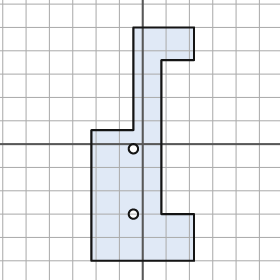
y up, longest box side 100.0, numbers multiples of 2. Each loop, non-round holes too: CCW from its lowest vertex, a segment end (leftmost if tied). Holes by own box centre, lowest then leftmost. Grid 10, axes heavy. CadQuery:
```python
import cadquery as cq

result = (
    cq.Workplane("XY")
    .moveTo(-22.0, -50.0)
    .lineTo(22.0, -50.0)
    .lineTo(22.0, -30.0)
    .lineTo(8.0, -30.0)
    .lineTo(8.0, 36.0)
    .lineTo(22.0, 36.0)
    .lineTo(22.0, 50.0)
    .lineTo(-4.0, 50.0)
    .lineTo(-4.0, 6.0)
    .lineTo(-22.0, 6.0)
    .close()
    .moveTo(-4.0, -30.0)
    .circle(2.0)
    .moveTo(-4.0, -2.0)
    .circle(2.0)
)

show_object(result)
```